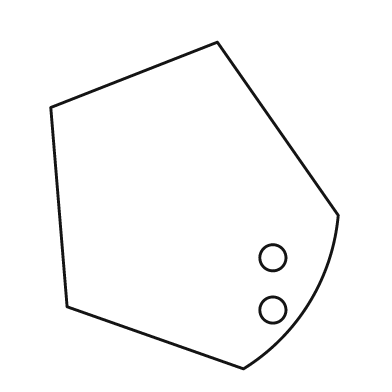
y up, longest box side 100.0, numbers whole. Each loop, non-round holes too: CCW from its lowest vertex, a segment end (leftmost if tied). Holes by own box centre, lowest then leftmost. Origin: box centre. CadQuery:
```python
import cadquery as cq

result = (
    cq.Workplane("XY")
    .moveTo(15.0, -50.0)
    .threePointArc((35.0, -30.0), (44.0, -3.0))
    .lineTo(7.0, 50.0)
    .lineTo(-44.0, 30.0)
    .lineTo(-39.0, -31.0)
    .close()
    .moveTo(24.0, -32.0)
    .circle(4.0)
    .moveTo(24.0, -16.0)
    .circle(4.0)
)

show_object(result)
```